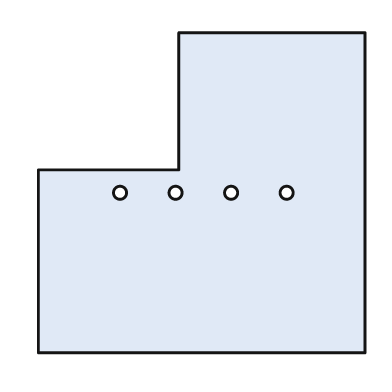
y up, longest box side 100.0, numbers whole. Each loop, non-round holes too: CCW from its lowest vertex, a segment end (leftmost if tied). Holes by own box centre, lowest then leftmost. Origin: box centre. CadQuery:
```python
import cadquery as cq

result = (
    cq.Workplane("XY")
    .moveTo(-50.0, -49.0)
    .lineTo(50.0, -49.0)
    .lineTo(50.0, 49.0)
    .lineTo(-7.0, 49.0)
    .lineTo(-7.0, 7.0)
    .lineTo(-50.0, 7.0)
    .close()
    .moveTo(-25.0, 0.0)
    .circle(2.0)
    .moveTo(-8.0, 0.0)
    .circle(2.0)
    .moveTo(9.0, 0.0)
    .circle(2.0)
    .moveTo(26.0, 0.0)
    .circle(2.0)
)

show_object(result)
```